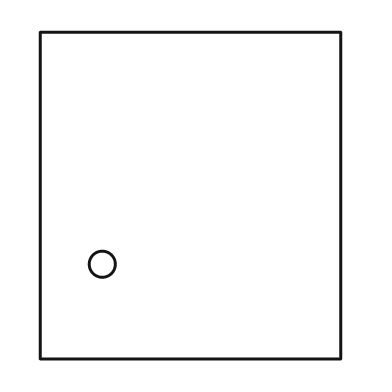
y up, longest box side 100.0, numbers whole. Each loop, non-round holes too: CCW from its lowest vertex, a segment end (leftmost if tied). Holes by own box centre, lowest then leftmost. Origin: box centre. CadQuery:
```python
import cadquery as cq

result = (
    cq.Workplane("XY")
    .moveTo(-46.0, -50.0)
    .lineTo(46.0, -50.0)
    .lineTo(46.0, 50.0)
    .lineTo(-46.0, 50.0)
    .close()
    .moveTo(-27.0, -21.0)
    .circle(4.0)
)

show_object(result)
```